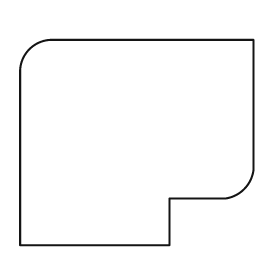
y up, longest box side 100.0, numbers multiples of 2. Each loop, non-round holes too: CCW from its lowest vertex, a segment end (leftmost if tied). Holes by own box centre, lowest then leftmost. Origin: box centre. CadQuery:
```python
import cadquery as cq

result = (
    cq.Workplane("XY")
    .moveTo(-50.0, -44.0)
    .lineTo(14.0, -44.0)
    .lineTo(14.0, -24.0)
    .lineTo(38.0, -24.0)
    .threePointArc((46.0, -20.0), (50.0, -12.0))
    .lineTo(50.0, 44.0)
    .lineTo(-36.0, 44.0)
    .threePointArc((-46.0, 40.0), (-50.0, 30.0))
    .close()
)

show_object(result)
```